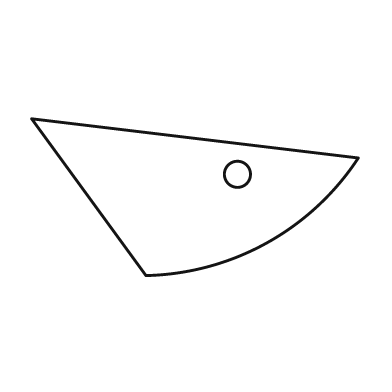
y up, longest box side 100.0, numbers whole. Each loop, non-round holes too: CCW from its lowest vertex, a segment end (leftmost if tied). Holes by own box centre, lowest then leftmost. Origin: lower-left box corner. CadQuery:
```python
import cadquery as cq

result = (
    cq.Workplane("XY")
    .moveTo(35.0, 0.0)
    .threePointArc((72.0, 10.0), (100.0, 36.0))
    .lineTo(0.0, 48.0)
    .close()
    .moveTo(63.0, 31.0)
    .circle(4.0)
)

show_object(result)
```